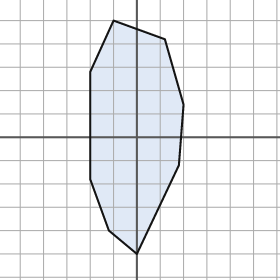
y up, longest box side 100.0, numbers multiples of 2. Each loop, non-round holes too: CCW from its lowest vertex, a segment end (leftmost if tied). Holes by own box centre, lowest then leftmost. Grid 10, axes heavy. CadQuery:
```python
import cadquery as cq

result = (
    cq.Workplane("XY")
    .moveTo(0.0, -50.0)
    .lineTo(18.0, -12.0)
    .lineTo(20.0, 14.0)
    .lineTo(12.0, 42.0)
    .lineTo(-10.0, 50.0)
    .lineTo(-20.0, 28.0)
    .lineTo(-20.0, -18.0)
    .lineTo(-12.0, -40.0)
    .close()
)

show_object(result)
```